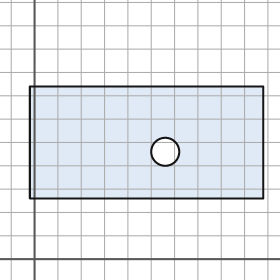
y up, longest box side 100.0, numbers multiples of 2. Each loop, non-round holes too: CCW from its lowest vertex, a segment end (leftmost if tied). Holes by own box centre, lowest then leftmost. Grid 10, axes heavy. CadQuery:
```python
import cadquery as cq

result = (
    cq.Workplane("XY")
    .moveTo(-2.0, 26.0)
    .lineTo(98.0, 26.0)
    .lineTo(98.0, 74.0)
    .lineTo(-2.0, 74.0)
    .close()
    .moveTo(56.0, 46.0)
    .circle(6.0)
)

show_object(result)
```